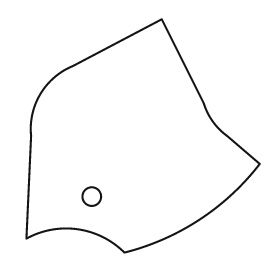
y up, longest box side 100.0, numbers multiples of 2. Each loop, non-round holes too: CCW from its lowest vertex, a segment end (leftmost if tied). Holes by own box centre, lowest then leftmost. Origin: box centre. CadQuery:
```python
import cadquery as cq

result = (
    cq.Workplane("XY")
    .moveTo(-8.0, -50.0)
    .threePointArc((24.0, -36.0), (50.0, -12.0))
    .lineTo(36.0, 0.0)
    .threePointArc((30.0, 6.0), (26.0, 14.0))
    .lineTo(8.0, 50.0)
    .lineTo(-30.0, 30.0)
    .threePointArc((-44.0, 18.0), (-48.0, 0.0))
    .lineTo(-50.0, -44.0)
    .threePointArc((-28.0, -40.0), (-8.0, -50.0))
    .close()
    .moveTo(-22.0, -26.0)
    .circle(4.0)
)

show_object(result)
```